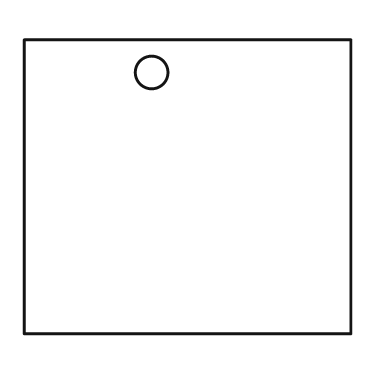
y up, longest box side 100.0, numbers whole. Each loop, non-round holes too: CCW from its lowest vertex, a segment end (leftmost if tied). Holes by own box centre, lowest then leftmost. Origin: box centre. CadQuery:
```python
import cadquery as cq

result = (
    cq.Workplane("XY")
    .moveTo(-50.0, -45.0)
    .lineTo(50.0, -45.0)
    .lineTo(50.0, 45.0)
    .lineTo(-50.0, 45.0)
    .close()
    .moveTo(-11.0, 35.0)
    .circle(5.0)
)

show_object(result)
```